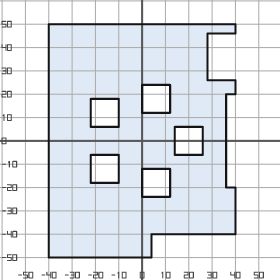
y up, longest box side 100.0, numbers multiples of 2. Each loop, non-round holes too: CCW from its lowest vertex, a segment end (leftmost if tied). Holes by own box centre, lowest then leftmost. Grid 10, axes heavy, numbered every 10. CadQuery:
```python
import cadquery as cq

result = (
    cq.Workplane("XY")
    .moveTo(-40.0, -50.0)
    .lineTo(4.0, -50.0)
    .lineTo(4.0, -40.0)
    .lineTo(40.0, -40.0)
    .lineTo(40.0, -20.0)
    .lineTo(36.0, -20.0)
    .lineTo(36.0, 20.0)
    .lineTo(40.0, 20.0)
    .lineTo(40.0, 26.0)
    .lineTo(28.0, 26.0)
    .lineTo(28.0, 46.0)
    .lineTo(40.0, 46.0)
    .lineTo(40.0, 50.0)
    .lineTo(-40.0, 50.0)
    .close()
    .moveTo(0.0, -24.0)
    .lineTo(12.0, -24.0)
    .lineTo(12.0, -12.0)
    .lineTo(0.0, -12.0)
    .close()
    .moveTo(-22.0, -18.0)
    .lineTo(-10.0, -18.0)
    .lineTo(-10.0, -6.0)
    .lineTo(-22.0, -6.0)
    .close()
    .moveTo(14.0, -6.0)
    .lineTo(26.0, -6.0)
    .lineTo(26.0, 6.0)
    .lineTo(14.0, 6.0)
    .close()
    .moveTo(-22.0, 6.0)
    .lineTo(-10.0, 6.0)
    .lineTo(-10.0, 18.0)
    .lineTo(-22.0, 18.0)
    .close()
    .moveTo(0.0, 12.0)
    .lineTo(12.0, 12.0)
    .lineTo(12.0, 24.0)
    .lineTo(0.0, 24.0)
    .close()
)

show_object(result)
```